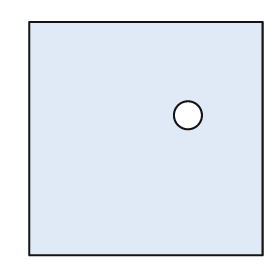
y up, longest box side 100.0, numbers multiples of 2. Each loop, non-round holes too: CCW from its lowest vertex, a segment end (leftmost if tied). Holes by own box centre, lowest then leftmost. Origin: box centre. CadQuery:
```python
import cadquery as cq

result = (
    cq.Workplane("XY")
    .moveTo(-50.0, -50.0)
    .lineTo(50.0, -50.0)
    .lineTo(50.0, 50.0)
    .lineTo(-50.0, 50.0)
    .close()
    .moveTo(18.0, 10.0)
    .circle(6.0)
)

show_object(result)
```